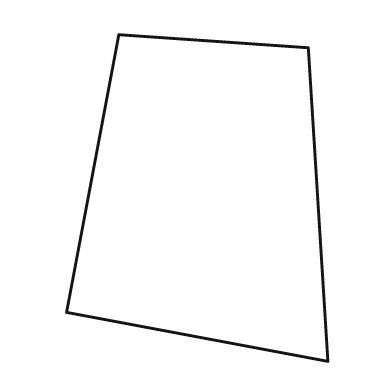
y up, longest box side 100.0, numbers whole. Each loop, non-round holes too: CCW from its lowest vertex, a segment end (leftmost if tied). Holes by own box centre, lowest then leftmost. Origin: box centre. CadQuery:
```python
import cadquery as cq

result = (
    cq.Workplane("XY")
    .moveTo(40.0, -50.0)
    .lineTo(34.0, 46.0)
    .lineTo(-24.0, 50.0)
    .lineTo(-40.0, -35.0)
    .close()
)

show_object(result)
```